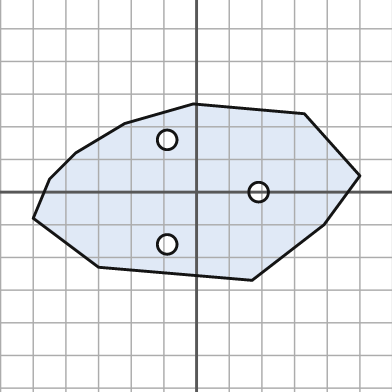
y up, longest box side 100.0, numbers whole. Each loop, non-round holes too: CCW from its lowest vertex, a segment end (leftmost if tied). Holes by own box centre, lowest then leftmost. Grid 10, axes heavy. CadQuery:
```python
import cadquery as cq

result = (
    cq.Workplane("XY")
    .moveTo(17.0, -27.0)
    .lineTo(39.0, -10.0)
    .lineTo(50.0, 5.0)
    .lineTo(33.0, 24.0)
    .lineTo(-1.0, 27.0)
    .lineTo(-22.0, 21.0)
    .lineTo(-37.0, 12.0)
    .lineTo(-45.0, 4.0)
    .lineTo(-50.0, -8.0)
    .lineTo(-30.0, -23.0)
    .close()
    .moveTo(-9.0, -16.0)
    .circle(3.0)
    .moveTo(19.0, 0.0)
    .circle(3.0)
    .moveTo(-9.0, 16.0)
    .circle(3.0)
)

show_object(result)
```